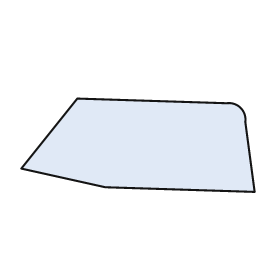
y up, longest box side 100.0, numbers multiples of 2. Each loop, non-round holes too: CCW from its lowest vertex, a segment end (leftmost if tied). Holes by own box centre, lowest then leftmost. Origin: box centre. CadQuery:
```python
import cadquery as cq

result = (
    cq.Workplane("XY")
    .moveTo(50.0, -20.0)
    .lineTo(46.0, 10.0)
    .threePointArc((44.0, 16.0), (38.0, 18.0))
    .lineTo(-26.0, 20.0)
    .lineTo(-50.0, -10.0)
    .lineTo(-14.0, -18.0)
    .close()
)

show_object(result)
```